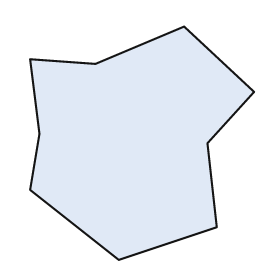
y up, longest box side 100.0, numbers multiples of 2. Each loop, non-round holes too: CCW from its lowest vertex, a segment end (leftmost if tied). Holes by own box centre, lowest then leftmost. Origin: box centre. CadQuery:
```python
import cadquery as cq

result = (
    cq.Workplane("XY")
    .moveTo(-10.0, -50.0)
    .lineTo(32.0, -36.0)
    .lineTo(28.0, 0.0)
    .lineTo(48.0, 22.0)
    .lineTo(18.0, 50.0)
    .lineTo(-20.0, 34.0)
    .lineTo(-48.0, 36.0)
    .lineTo(-44.0, 4.0)
    .lineTo(-48.0, -20.0)
    .close()
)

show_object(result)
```